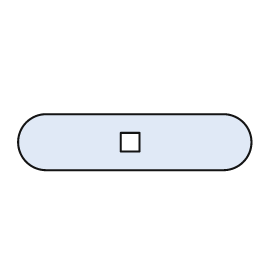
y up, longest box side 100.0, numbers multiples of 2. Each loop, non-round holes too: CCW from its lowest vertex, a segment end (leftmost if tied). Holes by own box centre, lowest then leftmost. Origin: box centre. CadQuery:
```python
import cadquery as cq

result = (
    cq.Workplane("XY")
    .moveTo(-38.0, -12.0)
    .lineTo(38.0, -12.0)
    .threePointArc((50.0, 0.0), (38.0, 12.0))
    .lineTo(-38.0, 12.0)
    .threePointArc((-50.0, 0.0), (-38.0, -12.0))
    .close()
    .moveTo(-6.0, -4.0)
    .lineTo(2.0, -4.0)
    .lineTo(2.0, 4.0)
    .lineTo(-6.0, 4.0)
    .close()
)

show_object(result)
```